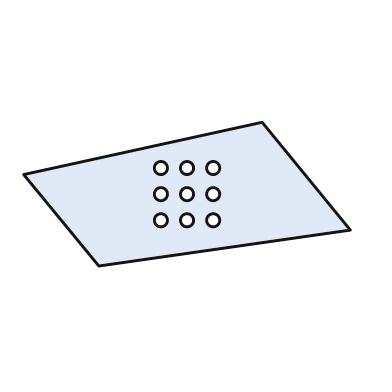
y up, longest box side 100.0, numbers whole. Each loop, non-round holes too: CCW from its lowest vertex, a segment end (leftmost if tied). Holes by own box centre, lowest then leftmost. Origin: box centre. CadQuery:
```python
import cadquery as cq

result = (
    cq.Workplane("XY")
    .moveTo(-27.0, -22.0)
    .lineTo(50.0, -11.0)
    .lineTo(23.0, 22.0)
    .lineTo(-50.0, 6.0)
    .close()
    .moveTo(-8.0, -8.0)
    .circle(2.0)
    .moveTo(0.0, -8.0)
    .circle(2.0)
    .moveTo(8.0, -8.0)
    .circle(2.0)
    .moveTo(-8.0, 0.0)
    .circle(2.0)
    .moveTo(0.0, 0.0)
    .circle(2.0)
    .moveTo(8.0, 0.0)
    .circle(2.0)
    .moveTo(-8.0, 8.0)
    .circle(2.0)
    .moveTo(0.0, 8.0)
    .circle(2.0)
    .moveTo(8.0, 8.0)
    .circle(2.0)
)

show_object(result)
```